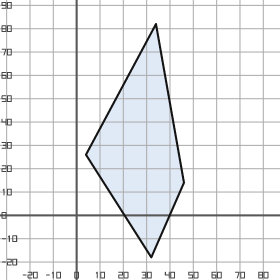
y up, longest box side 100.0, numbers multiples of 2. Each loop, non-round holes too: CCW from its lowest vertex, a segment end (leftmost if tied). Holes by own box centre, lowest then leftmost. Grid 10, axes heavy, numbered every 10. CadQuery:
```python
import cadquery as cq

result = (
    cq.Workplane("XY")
    .moveTo(32.0, -18.0)
    .lineTo(46.0, 14.0)
    .lineTo(34.0, 82.0)
    .lineTo(4.0, 26.0)
    .close()
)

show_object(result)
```